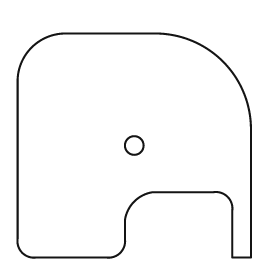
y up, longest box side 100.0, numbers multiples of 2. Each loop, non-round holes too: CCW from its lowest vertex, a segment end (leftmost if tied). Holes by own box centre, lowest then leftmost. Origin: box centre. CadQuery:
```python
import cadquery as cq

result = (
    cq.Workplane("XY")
    .moveTo(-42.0, -48.0)
    .lineTo(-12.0, -48.0)
    .threePointArc((-6.0, -46.0), (-4.0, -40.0))
    .lineTo(-4.0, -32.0)
    .threePointArc((0.0, -24.0), (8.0, -20.0))
    .lineTo(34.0, -20.0)
    .threePointArc((40.0, -22.0), (42.0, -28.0))
    .lineTo(42.0, -48.0)
    .lineTo(50.0, -48.0)
    .lineTo(50.0, 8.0)
    .threePointArc((38.0, 36.0), (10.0, 48.0))
    .lineTo(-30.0, 48.0)
    .threePointArc((-44.0, 42.0), (-50.0, 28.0))
    .lineTo(-50.0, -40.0)
    .threePointArc((-48.0, -46.0), (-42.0, -48.0))
    .close()
    .moveTo(0.0, 0.0)
    .circle(4.0)
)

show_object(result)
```